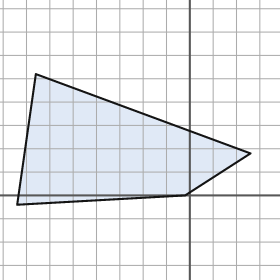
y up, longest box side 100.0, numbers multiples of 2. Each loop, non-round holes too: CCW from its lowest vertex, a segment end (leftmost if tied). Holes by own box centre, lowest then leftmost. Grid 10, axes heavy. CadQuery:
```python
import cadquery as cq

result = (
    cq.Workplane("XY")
    .moveTo(-74.0, -4.0)
    .lineTo(-2.0, 0.0)
    .lineTo(26.0, 18.0)
    .lineTo(-66.0, 52.0)
    .close()
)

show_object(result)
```